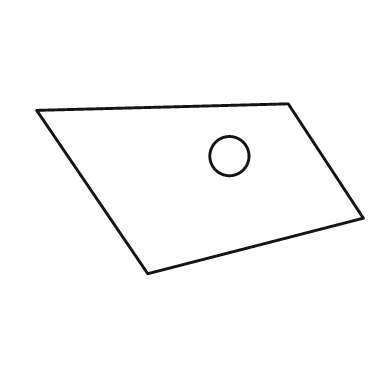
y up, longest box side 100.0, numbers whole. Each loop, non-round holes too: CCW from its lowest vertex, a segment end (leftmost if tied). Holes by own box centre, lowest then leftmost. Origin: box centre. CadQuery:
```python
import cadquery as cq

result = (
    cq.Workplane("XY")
    .moveTo(-16.0, -26.0)
    .lineTo(50.0, -9.0)
    .lineTo(27.0, 26.0)
    .lineTo(-50.0, 24.0)
    .close()
    .moveTo(9.0, 10.0)
    .circle(6.0)
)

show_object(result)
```